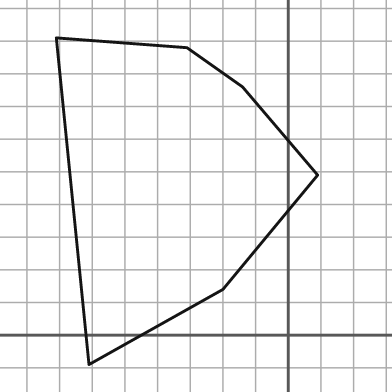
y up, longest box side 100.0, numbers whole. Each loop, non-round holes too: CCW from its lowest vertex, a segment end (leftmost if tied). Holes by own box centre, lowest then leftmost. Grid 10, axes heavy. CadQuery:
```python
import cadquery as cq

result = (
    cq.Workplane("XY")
    .moveTo(-61.0, -9.0)
    .lineTo(-20.0, 14.0)
    .lineTo(9.0, 49.0)
    .lineTo(-14.0, 76.0)
    .lineTo(-31.0, 88.0)
    .lineTo(-71.0, 91.0)
    .close()
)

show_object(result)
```